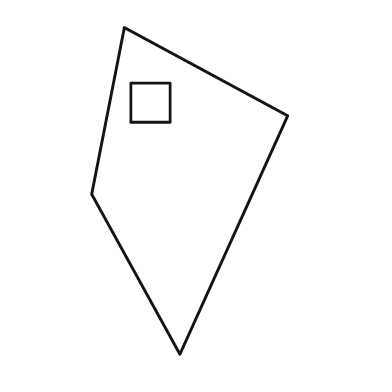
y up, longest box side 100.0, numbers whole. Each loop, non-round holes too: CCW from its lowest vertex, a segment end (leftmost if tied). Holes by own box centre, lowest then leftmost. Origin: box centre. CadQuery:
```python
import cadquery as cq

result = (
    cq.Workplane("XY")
    .moveTo(-3.0, -50.0)
    .lineTo(30.0, 23.0)
    .lineTo(-20.0, 50.0)
    .lineTo(-30.0, -1.0)
    .close()
    .moveTo(-18.0, 21.0)
    .lineTo(-6.0, 21.0)
    .lineTo(-6.0, 33.0)
    .lineTo(-18.0, 33.0)
    .close()
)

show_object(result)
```